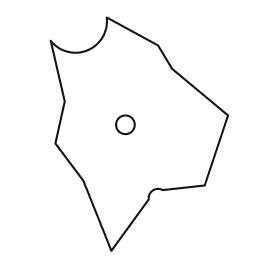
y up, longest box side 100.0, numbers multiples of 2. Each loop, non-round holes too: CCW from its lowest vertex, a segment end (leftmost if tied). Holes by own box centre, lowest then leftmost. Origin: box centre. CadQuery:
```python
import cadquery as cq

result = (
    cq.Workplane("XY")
    .moveTo(-12.0, -50.0)
    .lineTo(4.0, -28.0)
    .threePointArc((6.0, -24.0), (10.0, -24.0))
    .lineTo(28.0, -22.0)
    .lineTo(38.0, 8.0)
    .lineTo(14.0, 28.0)
    .lineTo(8.0, 38.0)
    .lineTo(-14.0, 50.0)
    .threePointArc((-22.0, 36.0), (-38.0, 40.0))
    .lineTo(-32.0, 14.0)
    .lineTo(-36.0, -4.0)
    .lineTo(-24.0, -20.0)
    .close()
    .moveTo(-6.0, 4.0)
    .circle(4.0)
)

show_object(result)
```